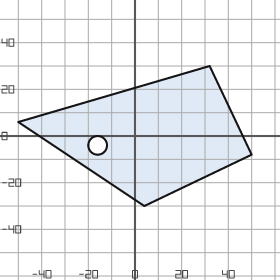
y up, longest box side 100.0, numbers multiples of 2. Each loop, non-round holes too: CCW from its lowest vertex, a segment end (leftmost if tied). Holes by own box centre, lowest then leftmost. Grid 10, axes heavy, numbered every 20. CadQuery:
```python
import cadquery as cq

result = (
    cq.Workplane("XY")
    .moveTo(4.0, -30.0)
    .lineTo(50.0, -8.0)
    .lineTo(32.0, 30.0)
    .lineTo(-50.0, 6.0)
    .close()
    .moveTo(-16.0, -4.0)
    .circle(4.0)
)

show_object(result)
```